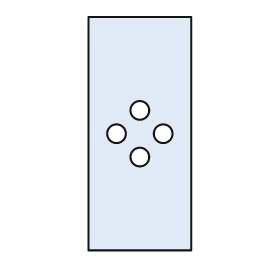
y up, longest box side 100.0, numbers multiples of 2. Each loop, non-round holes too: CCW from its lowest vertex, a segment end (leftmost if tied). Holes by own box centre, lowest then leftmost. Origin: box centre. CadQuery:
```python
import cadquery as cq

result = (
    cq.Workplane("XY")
    .moveTo(-22.0, -50.0)
    .lineTo(22.0, -50.0)
    .lineTo(22.0, 50.0)
    .lineTo(-22.0, 50.0)
    .close()
    .moveTo(0.0, -10.0)
    .circle(4.0)
    .moveTo(-10.0, 0.0)
    .circle(4.0)
    .moveTo(10.0, 0.0)
    .circle(4.0)
    .moveTo(0.0, 10.0)
    .circle(4.0)
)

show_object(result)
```